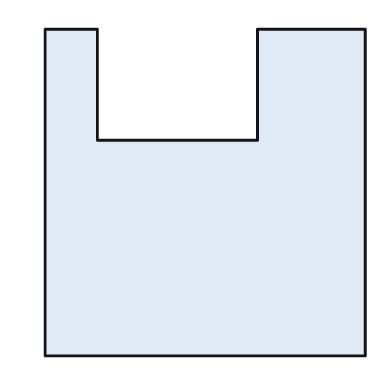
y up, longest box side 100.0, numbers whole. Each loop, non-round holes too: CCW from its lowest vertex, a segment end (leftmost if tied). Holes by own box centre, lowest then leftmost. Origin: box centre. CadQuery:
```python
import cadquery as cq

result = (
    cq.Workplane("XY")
    .moveTo(-49.0, -50.0)
    .lineTo(49.0, -50.0)
    .lineTo(49.0, 50.0)
    .lineTo(16.0, 50.0)
    .lineTo(16.0, 16.0)
    .lineTo(-33.0, 16.0)
    .lineTo(-33.0, 50.0)
    .lineTo(-49.0, 50.0)
    .close()
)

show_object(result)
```